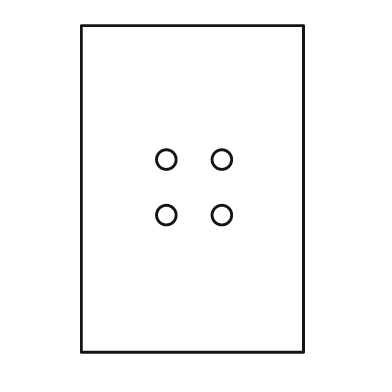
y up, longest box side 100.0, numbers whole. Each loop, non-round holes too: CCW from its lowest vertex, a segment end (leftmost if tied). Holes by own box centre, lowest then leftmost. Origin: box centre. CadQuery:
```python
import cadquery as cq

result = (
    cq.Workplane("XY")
    .moveTo(-34.0, -50.0)
    .lineTo(34.0, -50.0)
    .lineTo(34.0, 50.0)
    .lineTo(-34.0, 50.0)
    .close()
    .moveTo(-8.0, -8.0)
    .circle(3.0)
    .moveTo(9.0, -8.0)
    .circle(3.0)
    .moveTo(-8.0, 9.0)
    .circle(3.0)
    .moveTo(9.0, 9.0)
    .circle(3.0)
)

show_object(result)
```